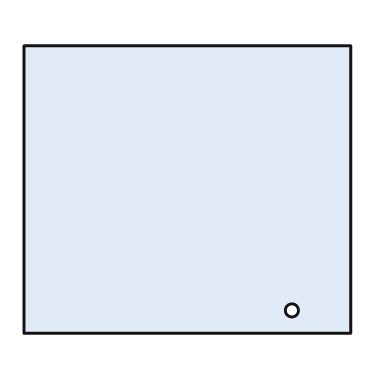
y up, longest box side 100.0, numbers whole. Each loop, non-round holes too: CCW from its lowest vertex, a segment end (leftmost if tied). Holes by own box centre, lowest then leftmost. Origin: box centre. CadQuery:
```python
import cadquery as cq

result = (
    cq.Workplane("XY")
    .moveTo(-50.0, -44.0)
    .lineTo(50.0, -44.0)
    .lineTo(50.0, 44.0)
    .lineTo(-50.0, 44.0)
    .close()
    .moveTo(32.0, -37.0)
    .circle(2.0)
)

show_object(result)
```